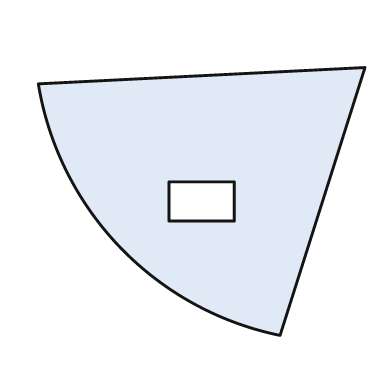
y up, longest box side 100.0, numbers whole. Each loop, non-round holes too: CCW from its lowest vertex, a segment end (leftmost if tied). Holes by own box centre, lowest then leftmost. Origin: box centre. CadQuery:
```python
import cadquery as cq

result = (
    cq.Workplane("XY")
    .moveTo(24.0, -41.0)
    .lineTo(50.0, 41.0)
    .lineTo(-50.0, 36.0)
    .threePointArc((-25.0, -14.0), (24.0, -41.0))
    .close()
    .moveTo(-10.0, -6.0)
    .lineTo(10.0, -6.0)
    .lineTo(10.0, 6.0)
    .lineTo(-10.0, 6.0)
    .close()
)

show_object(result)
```